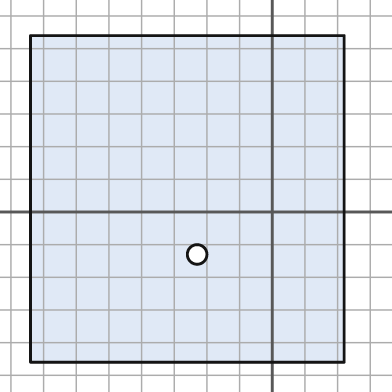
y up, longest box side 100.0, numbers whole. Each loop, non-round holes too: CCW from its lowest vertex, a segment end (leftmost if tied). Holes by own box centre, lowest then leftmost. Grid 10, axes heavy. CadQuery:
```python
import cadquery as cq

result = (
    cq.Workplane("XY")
    .moveTo(-74.0, -46.0)
    .lineTo(22.0, -46.0)
    .lineTo(22.0, 54.0)
    .lineTo(-74.0, 54.0)
    .close()
    .moveTo(-23.0, -13.0)
    .circle(3.0)
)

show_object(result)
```